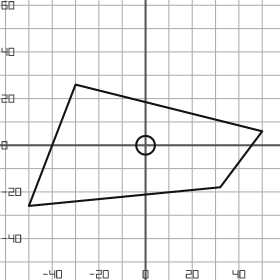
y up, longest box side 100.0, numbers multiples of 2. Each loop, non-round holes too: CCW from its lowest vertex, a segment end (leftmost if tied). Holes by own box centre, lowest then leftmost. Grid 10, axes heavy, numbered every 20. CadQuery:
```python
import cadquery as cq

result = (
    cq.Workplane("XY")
    .moveTo(-50.0, -26.0)
    .lineTo(32.0, -18.0)
    .lineTo(50.0, 6.0)
    .lineTo(-30.0, 26.0)
    .close()
    .moveTo(0.0, 0.0)
    .circle(4.0)
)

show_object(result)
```